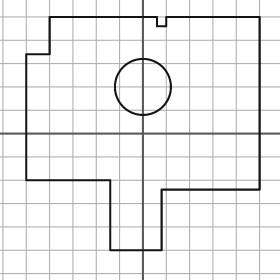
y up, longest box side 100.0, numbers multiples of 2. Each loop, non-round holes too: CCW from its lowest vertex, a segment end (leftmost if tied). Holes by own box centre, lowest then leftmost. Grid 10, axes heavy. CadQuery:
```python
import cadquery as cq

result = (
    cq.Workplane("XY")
    .moveTo(-14.0, -50.0)
    .lineTo(8.0, -50.0)
    .lineTo(8.0, -24.0)
    .lineTo(50.0, -24.0)
    .lineTo(50.0, 50.0)
    .lineTo(10.0, 50.0)
    .lineTo(10.0, 46.0)
    .lineTo(6.0, 46.0)
    .lineTo(6.0, 50.0)
    .lineTo(-40.0, 50.0)
    .lineTo(-40.0, 34.0)
    .lineTo(-50.0, 34.0)
    .lineTo(-50.0, -20.0)
    .lineTo(-14.0, -20.0)
    .close()
    .moveTo(0.0, 20.0)
    .circle(12.0)
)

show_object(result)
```